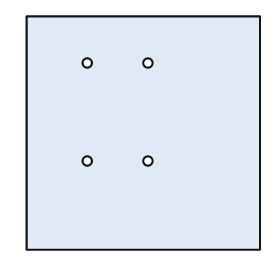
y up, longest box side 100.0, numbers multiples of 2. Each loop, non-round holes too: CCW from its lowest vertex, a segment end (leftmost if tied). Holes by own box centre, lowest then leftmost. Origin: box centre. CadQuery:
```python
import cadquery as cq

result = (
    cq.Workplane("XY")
    .moveTo(-50.0, -50.0)
    .lineTo(50.0, -50.0)
    .lineTo(50.0, 50.0)
    .lineTo(-50.0, 50.0)
    .close()
    .moveTo(-24.0, -12.0)
    .circle(2.0)
    .moveTo(2.0, -12.0)
    .circle(2.0)
    .moveTo(-24.0, 30.0)
    .circle(2.0)
    .moveTo(2.0, 30.0)
    .circle(2.0)
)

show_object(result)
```